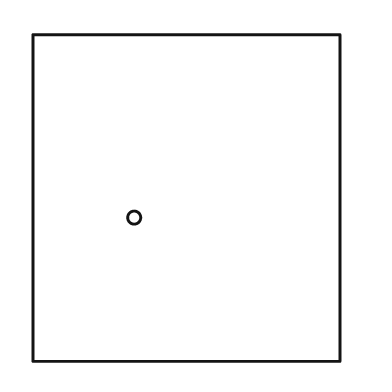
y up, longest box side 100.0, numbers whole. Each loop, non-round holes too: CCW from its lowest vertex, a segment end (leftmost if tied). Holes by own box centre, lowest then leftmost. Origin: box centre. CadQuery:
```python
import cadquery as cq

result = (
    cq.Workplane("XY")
    .moveTo(-47.0, -50.0)
    .lineTo(47.0, -50.0)
    .lineTo(47.0, 50.0)
    .lineTo(-47.0, 50.0)
    .close()
    .moveTo(-16.0, -6.0)
    .circle(2.0)
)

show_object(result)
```